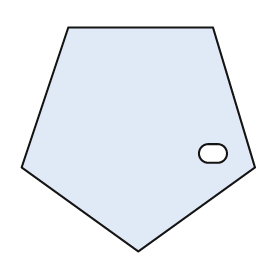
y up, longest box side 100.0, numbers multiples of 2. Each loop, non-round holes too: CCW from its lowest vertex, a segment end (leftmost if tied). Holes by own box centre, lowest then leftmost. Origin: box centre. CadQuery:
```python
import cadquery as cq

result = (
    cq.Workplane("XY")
    .moveTo(0.0, -48.0)
    .lineTo(50.0, -12.0)
    .lineTo(32.0, 48.0)
    .lineTo(-30.0, 48.0)
    .lineTo(-50.0, -12.0)
    .close()
    .moveTo(30.0, -10.0)
    .lineTo(34.0, -10.0)
    .threePointArc((38.0, -6.0), (34.0, -2.0))
    .lineTo(30.0, -2.0)
    .threePointArc((26.0, -6.0), (30.0, -10.0))
    .close()
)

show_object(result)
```